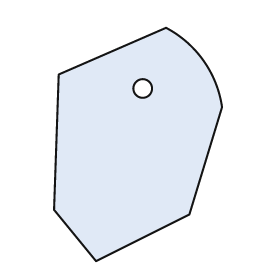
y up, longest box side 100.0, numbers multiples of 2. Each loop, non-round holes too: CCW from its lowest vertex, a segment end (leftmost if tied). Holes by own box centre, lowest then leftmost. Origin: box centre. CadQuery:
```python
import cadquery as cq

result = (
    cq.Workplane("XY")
    .moveTo(-18.0, -50.0)
    .lineTo(22.0, -30.0)
    .lineTo(36.0, 16.0)
    .threePointArc((28.0, 36.0), (12.0, 50.0))
    .lineTo(-34.0, 30.0)
    .lineTo(-36.0, -28.0)
    .close()
    .moveTo(2.0, 24.0)
    .circle(4.0)
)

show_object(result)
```